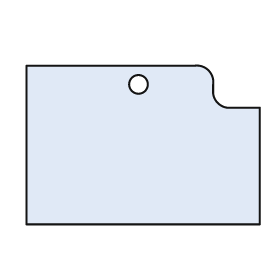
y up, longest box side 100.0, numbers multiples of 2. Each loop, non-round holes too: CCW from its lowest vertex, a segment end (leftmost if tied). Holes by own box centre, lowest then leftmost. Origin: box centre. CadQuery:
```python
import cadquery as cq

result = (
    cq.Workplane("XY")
    .moveTo(-50.0, -34.0)
    .lineTo(50.0, -34.0)
    .lineTo(50.0, 16.0)
    .lineTo(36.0, 16.0)
    .threePointArc((32.0, 18.0), (30.0, 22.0))
    .lineTo(30.0, 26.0)
    .threePointArc((28.0, 32.0), (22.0, 34.0))
    .lineTo(-50.0, 34.0)
    .close()
    .moveTo(-2.0, 26.0)
    .circle(4.0)
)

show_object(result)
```